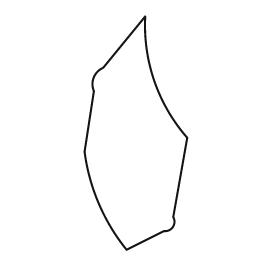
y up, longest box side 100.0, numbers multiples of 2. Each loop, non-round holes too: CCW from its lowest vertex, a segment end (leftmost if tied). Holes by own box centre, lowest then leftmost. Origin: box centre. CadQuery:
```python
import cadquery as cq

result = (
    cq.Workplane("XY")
    .moveTo(-4.0, -50.0)
    .lineTo(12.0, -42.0)
    .threePointArc((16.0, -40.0), (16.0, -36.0))
    .lineTo(22.0, -2.0)
    .threePointArc((8.0, 22.0), (4.0, 50.0))
    .lineTo(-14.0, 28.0)
    .threePointArc((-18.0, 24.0), (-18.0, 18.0))
    .lineTo(-22.0, -8.0)
    .threePointArc((-16.0, -30.0), (-4.0, -50.0))
    .close()
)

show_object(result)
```